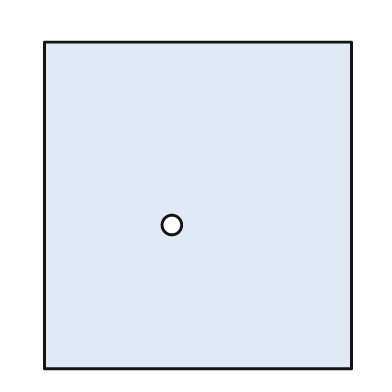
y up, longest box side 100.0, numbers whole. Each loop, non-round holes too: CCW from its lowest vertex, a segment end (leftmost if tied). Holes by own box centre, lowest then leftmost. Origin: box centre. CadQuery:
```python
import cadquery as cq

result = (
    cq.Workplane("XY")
    .moveTo(-47.0, -50.0)
    .lineTo(47.0, -50.0)
    .lineTo(47.0, 50.0)
    .lineTo(-47.0, 50.0)
    .close()
    .moveTo(-8.0, -6.0)
    .circle(3.0)
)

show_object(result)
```